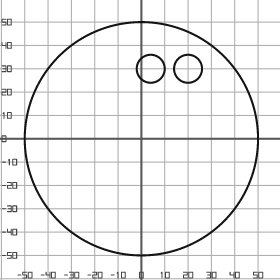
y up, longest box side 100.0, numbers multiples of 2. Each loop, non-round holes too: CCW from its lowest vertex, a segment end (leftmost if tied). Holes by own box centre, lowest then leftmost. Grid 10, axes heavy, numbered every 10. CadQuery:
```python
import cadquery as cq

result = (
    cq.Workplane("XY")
    .moveTo(0.0, 0.0)
    .circle(50.0)
    .moveTo(4.0, 30.0)
    .circle(6.0)
    .moveTo(20.0, 30.0)
    .circle(6.0)
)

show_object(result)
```